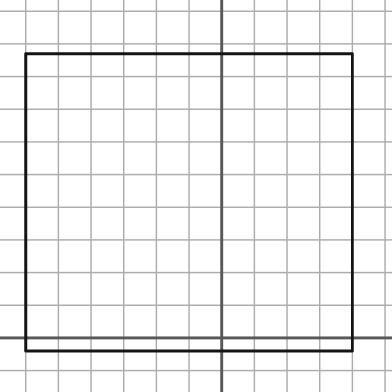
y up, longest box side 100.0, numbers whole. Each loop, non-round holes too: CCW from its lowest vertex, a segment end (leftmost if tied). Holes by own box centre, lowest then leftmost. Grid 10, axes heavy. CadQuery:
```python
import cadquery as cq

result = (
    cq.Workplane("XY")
    .moveTo(-60.0, -4.0)
    .lineTo(40.0, -4.0)
    .lineTo(40.0, 87.0)
    .lineTo(-60.0, 87.0)
    .close()
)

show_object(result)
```